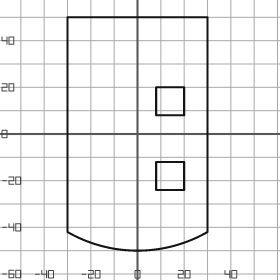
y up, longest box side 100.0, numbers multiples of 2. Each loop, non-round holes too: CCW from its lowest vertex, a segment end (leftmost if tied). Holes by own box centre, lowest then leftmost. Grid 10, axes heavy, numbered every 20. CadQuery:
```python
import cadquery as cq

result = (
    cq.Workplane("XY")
    .moveTo(-30.0, -42.0)
    .threePointArc((0.0, -50.0), (30.0, -42.0))
    .lineTo(30.0, 50.0)
    .lineTo(-30.0, 50.0)
    .close()
    .moveTo(8.0, -24.0)
    .lineTo(20.0, -24.0)
    .lineTo(20.0, -12.0)
    .lineTo(8.0, -12.0)
    .close()
    .moveTo(8.0, 8.0)
    .lineTo(20.0, 8.0)
    .lineTo(20.0, 20.0)
    .lineTo(8.0, 20.0)
    .close()
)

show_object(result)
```